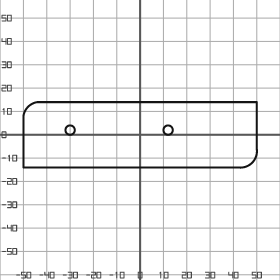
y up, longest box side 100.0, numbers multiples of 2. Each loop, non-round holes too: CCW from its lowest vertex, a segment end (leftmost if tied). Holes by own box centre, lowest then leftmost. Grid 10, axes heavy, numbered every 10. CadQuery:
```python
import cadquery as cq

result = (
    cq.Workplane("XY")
    .moveTo(-50.0, -14.0)
    .lineTo(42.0, -14.0)
    .threePointArc((48.0, -12.0), (50.0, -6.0))
    .lineTo(50.0, 14.0)
    .lineTo(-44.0, 14.0)
    .threePointArc((-48.0, 12.0), (-50.0, 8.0))
    .close()
    .moveTo(-30.0, 2.0)
    .circle(2.0)
    .moveTo(12.0, 2.0)
    .circle(2.0)
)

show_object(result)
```